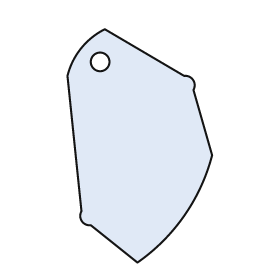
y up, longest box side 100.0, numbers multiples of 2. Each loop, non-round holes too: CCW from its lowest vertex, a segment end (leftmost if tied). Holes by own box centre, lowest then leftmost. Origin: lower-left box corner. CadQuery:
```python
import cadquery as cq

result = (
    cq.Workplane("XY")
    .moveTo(30.0, 0.0)
    .threePointArc((50.0, 20.0), (62.0, 46.0))
    .lineTo(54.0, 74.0)
    .threePointArc((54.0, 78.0), (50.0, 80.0))
    .lineTo(16.0, 100.0)
    .threePointArc((6.0, 92.0), (0.0, 80.0))
    .lineTo(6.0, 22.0)
    .threePointArc((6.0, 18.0), (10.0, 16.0))
    .close()
    .moveTo(14.0, 86.0)
    .circle(4.0)
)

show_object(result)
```